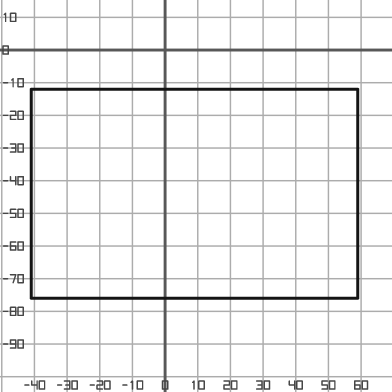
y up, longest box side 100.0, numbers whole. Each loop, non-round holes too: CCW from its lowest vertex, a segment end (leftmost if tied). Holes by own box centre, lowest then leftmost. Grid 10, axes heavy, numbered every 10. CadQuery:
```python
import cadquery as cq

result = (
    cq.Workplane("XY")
    .moveTo(-41.0, -76.0)
    .lineTo(59.0, -76.0)
    .lineTo(59.0, -12.0)
    .lineTo(-41.0, -12.0)
    .close()
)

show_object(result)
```